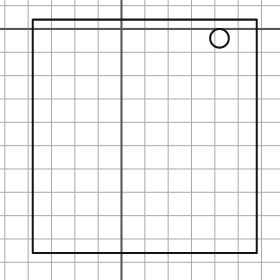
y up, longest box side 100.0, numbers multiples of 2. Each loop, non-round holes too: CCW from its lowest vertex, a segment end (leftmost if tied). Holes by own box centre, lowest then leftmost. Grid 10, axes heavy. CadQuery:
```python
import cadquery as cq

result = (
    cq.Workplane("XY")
    .moveTo(-38.0, -96.0)
    .lineTo(58.0, -96.0)
    .lineTo(58.0, 4.0)
    .lineTo(-38.0, 4.0)
    .close()
    .moveTo(42.0, -4.0)
    .circle(4.0)
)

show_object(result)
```